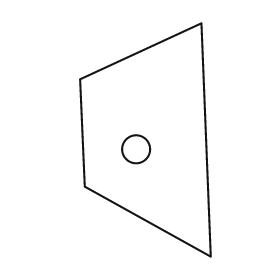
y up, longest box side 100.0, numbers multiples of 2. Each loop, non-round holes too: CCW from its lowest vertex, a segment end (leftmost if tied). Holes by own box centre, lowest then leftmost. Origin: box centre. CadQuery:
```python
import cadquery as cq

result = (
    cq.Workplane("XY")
    .moveTo(28.0, -50.0)
    .lineTo(24.0, 50.0)
    .lineTo(-28.0, 26.0)
    .lineTo(-26.0, -20.0)
    .close()
    .moveTo(-4.0, -4.0)
    .circle(6.0)
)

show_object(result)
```